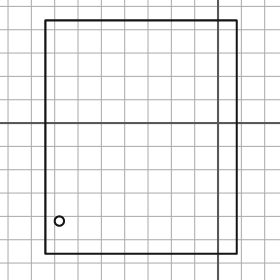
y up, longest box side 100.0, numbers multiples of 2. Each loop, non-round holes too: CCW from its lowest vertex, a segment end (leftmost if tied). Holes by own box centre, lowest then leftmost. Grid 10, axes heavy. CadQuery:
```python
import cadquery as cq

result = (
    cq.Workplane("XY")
    .moveTo(-74.0, -56.0)
    .lineTo(8.0, -56.0)
    .lineTo(8.0, 44.0)
    .lineTo(-74.0, 44.0)
    .close()
    .moveTo(-68.0, -42.0)
    .circle(2.0)
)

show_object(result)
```